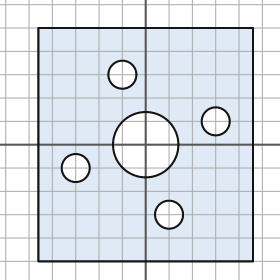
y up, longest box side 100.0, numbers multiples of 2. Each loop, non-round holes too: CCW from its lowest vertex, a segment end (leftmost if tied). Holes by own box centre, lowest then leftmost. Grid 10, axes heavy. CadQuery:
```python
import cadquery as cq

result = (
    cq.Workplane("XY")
    .moveTo(-46.0, -50.0)
    .lineTo(46.0, -50.0)
    .lineTo(46.0, 50.0)
    .lineTo(-46.0, 50.0)
    .close()
    .moveTo(10.0, -30.0)
    .circle(6.0)
    .moveTo(-30.0, -10.0)
    .circle(6.0)
    .moveTo(0.0, 0.0)
    .circle(14.0)
    .moveTo(30.0, 10.0)
    .circle(6.0)
    .moveTo(-10.0, 30.0)
    .circle(6.0)
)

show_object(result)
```